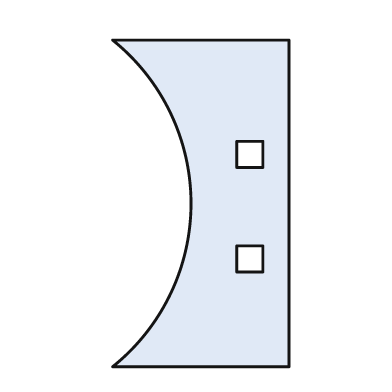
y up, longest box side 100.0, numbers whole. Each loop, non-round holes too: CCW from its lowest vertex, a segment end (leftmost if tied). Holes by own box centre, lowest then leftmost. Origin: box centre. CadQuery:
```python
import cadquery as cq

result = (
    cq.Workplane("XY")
    .moveTo(-27.0, -50.0)
    .lineTo(27.0, -50.0)
    .lineTo(27.0, 50.0)
    .lineTo(-27.0, 50.0)
    .threePointArc((-3.0, 0.0), (-27.0, -50.0))
    .close()
    .moveTo(11.0, -21.0)
    .lineTo(19.0, -21.0)
    .lineTo(19.0, -13.0)
    .lineTo(11.0, -13.0)
    .close()
    .moveTo(11.0, 11.0)
    .lineTo(19.0, 11.0)
    .lineTo(19.0, 19.0)
    .lineTo(11.0, 19.0)
    .close()
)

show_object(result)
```